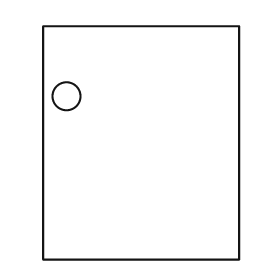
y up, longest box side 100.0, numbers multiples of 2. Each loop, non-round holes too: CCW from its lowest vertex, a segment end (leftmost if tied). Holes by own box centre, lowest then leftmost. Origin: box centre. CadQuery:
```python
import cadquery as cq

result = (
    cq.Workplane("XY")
    .moveTo(-42.0, -50.0)
    .lineTo(42.0, -50.0)
    .lineTo(42.0, 50.0)
    .lineTo(-42.0, 50.0)
    .close()
    .moveTo(-32.0, 20.0)
    .circle(6.0)
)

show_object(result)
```